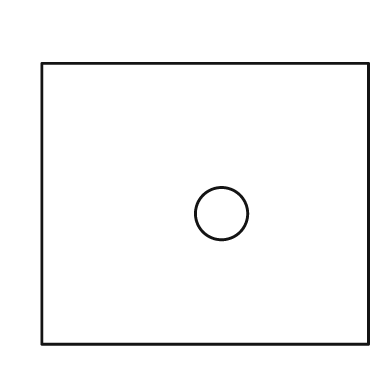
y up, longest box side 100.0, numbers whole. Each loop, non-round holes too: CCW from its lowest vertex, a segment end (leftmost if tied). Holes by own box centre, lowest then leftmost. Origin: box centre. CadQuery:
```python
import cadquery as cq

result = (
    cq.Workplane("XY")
    .moveTo(-50.0, -43.0)
    .lineTo(50.0, -43.0)
    .lineTo(50.0, 43.0)
    .lineTo(-50.0, 43.0)
    .close()
    .moveTo(5.0, -3.0)
    .circle(8.0)
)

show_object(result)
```